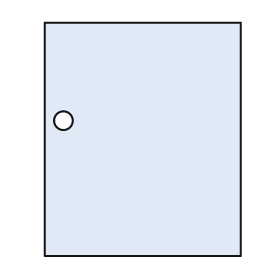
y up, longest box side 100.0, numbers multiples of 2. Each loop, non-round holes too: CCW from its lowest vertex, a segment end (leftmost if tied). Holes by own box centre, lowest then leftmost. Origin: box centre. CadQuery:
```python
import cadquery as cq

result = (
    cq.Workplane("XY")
    .moveTo(-42.0, -50.0)
    .lineTo(42.0, -50.0)
    .lineTo(42.0, 50.0)
    .lineTo(-42.0, 50.0)
    .close()
    .moveTo(-34.0, 8.0)
    .circle(4.0)
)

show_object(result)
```